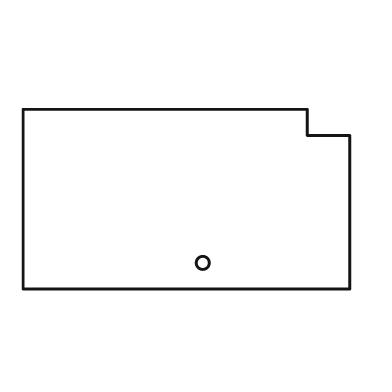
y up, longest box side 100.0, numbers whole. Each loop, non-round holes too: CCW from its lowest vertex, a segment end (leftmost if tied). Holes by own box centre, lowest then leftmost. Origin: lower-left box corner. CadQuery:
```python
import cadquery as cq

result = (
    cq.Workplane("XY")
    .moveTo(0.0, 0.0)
    .lineTo(100.0, 0.0)
    .lineTo(100.0, 47.0)
    .lineTo(87.0, 47.0)
    .lineTo(87.0, 55.0)
    .lineTo(0.0, 55.0)
    .close()
    .moveTo(55.0, 8.0)
    .circle(2.0)
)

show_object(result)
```